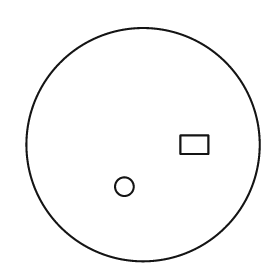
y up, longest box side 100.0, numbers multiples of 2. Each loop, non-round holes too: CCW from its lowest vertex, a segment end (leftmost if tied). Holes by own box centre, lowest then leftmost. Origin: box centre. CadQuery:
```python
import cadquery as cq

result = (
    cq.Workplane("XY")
    .moveTo(0.0, 0.0)
    .circle(50.0)
    .moveTo(-8.0, -18.0)
    .circle(4.0)
    .moveTo(16.0, -4.0)
    .lineTo(28.0, -4.0)
    .lineTo(28.0, 4.0)
    .lineTo(16.0, 4.0)
    .close()
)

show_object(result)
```